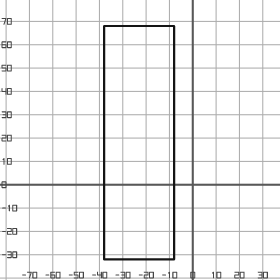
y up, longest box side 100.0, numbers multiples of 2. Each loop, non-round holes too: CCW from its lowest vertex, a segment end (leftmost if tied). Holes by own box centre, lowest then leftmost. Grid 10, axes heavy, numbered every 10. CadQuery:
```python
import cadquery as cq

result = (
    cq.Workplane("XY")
    .moveTo(-38.0, -32.0)
    .lineTo(-8.0, -32.0)
    .lineTo(-8.0, 68.0)
    .lineTo(-38.0, 68.0)
    .close()
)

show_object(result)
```